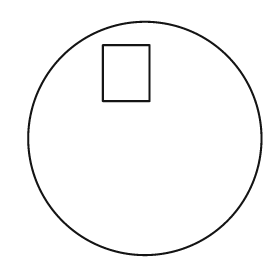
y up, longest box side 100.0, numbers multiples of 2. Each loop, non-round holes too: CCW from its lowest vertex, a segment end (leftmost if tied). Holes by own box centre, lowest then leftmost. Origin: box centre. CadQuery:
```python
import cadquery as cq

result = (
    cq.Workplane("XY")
    .moveTo(0.0, 0.0)
    .circle(50.0)
    .moveTo(-18.0, 16.0)
    .lineTo(2.0, 16.0)
    .lineTo(2.0, 40.0)
    .lineTo(-18.0, 40.0)
    .close()
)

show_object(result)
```